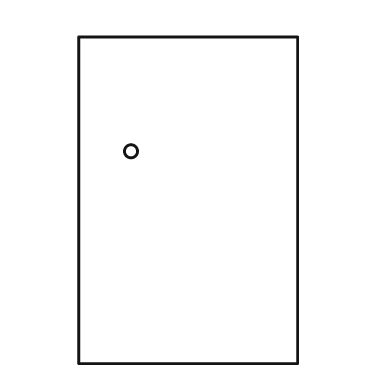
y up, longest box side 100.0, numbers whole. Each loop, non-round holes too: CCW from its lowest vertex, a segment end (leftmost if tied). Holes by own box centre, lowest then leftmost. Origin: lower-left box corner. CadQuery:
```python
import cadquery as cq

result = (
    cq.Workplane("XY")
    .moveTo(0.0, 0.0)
    .lineTo(67.0, 0.0)
    .lineTo(67.0, 100.0)
    .lineTo(0.0, 100.0)
    .close()
    .moveTo(16.0, 65.0)
    .circle(2.0)
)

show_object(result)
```